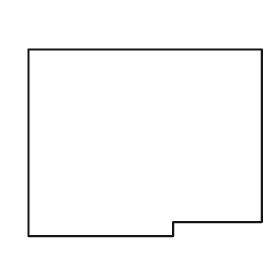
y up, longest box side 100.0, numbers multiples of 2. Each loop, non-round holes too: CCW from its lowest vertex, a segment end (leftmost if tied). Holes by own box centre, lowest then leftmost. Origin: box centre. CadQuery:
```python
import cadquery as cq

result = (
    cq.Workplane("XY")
    .moveTo(-50.0, -40.0)
    .lineTo(12.0, -40.0)
    .lineTo(12.0, -34.0)
    .lineTo(50.0, -34.0)
    .lineTo(50.0, 40.0)
    .lineTo(-50.0, 40.0)
    .close()
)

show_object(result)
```